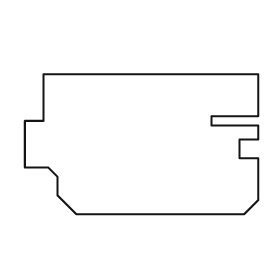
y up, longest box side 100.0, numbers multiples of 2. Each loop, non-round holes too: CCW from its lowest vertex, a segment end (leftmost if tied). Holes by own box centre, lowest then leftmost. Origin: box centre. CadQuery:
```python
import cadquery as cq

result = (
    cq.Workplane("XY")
    .moveTo(-28.0, -30.0)
    .lineTo(44.0, -30.0)
    .lineTo(50.0, -24.0)
    .lineTo(50.0, -6.0)
    .lineTo(42.0, -6.0)
    .lineTo(42.0, 2.0)
    .lineTo(50.0, 2.0)
    .lineTo(50.0, 8.0)
    .lineTo(30.0, 8.0)
    .lineTo(30.0, 12.0)
    .lineTo(50.0, 12.0)
    .lineTo(50.0, 30.0)
    .lineTo(-42.0, 30.0)
    .lineTo(-42.0, 10.0)
    .lineTo(-50.0, 10.0)
    .lineTo(-50.0, -10.0)
    .lineTo(-40.0, -10.0)
    .lineTo(-36.0, -14.0)
    .lineTo(-36.0, -22.0)
    .close()
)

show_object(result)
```